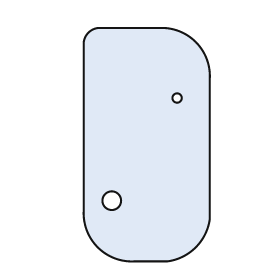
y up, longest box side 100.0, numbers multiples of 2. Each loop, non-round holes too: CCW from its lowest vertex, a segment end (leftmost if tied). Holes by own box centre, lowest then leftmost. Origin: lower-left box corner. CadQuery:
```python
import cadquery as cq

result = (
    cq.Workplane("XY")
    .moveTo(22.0, 0.0)
    .lineTo(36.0, 0.0)
    .threePointArc((48.0, 6.0), (54.0, 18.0))
    .lineTo(54.0, 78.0)
    .threePointArc((48.0, 94.0), (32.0, 100.0))
    .lineTo(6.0, 100.0)
    .threePointArc((2.0, 98.0), (0.0, 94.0))
    .lineTo(0.0, 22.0)
    .threePointArc((6.0, 6.0), (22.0, 0.0))
    .close()
    .moveTo(12.0, 26.0)
    .circle(4.0)
    .moveTo(40.0, 70.0)
    .circle(2.0)
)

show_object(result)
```